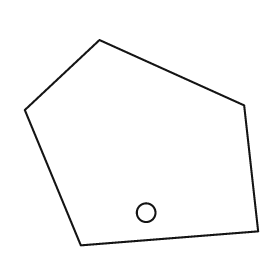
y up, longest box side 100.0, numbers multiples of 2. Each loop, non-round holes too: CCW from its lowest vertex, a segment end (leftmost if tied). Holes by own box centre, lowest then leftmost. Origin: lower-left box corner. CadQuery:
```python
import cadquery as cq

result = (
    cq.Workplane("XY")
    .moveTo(24.0, 0.0)
    .lineTo(100.0, 6.0)
    .lineTo(94.0, 60.0)
    .lineTo(32.0, 88.0)
    .lineTo(0.0, 58.0)
    .close()
    .moveTo(52.0, 14.0)
    .circle(4.0)
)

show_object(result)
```